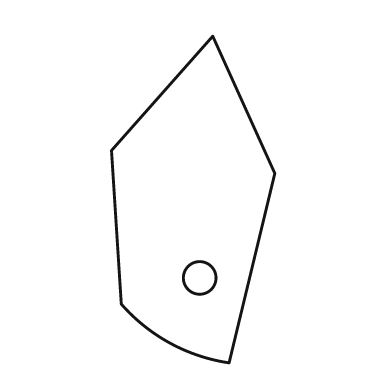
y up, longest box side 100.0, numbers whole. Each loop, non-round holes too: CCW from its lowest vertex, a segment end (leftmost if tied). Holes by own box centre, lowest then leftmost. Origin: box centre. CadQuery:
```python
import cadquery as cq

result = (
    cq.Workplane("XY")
    .moveTo(11.0, -50.0)
    .lineTo(25.0, 8.0)
    .lineTo(6.0, 50.0)
    .lineTo(-25.0, 15.0)
    .lineTo(-22.0, -32.0)
    .threePointArc((-7.0, -44.0), (11.0, -50.0))
    .close()
    .moveTo(2.0, -24.0)
    .circle(5.0)
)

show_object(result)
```